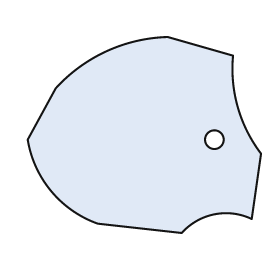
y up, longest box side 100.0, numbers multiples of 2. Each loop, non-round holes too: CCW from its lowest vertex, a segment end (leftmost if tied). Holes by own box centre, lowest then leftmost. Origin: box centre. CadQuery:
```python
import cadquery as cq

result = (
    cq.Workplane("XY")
    .moveTo(16.0, -42.0)
    .threePointArc((30.0, -34.0), (46.0, -36.0))
    .lineTo(50.0, -8.0)
    .threePointArc((40.0, 12.0), (38.0, 34.0))
    .lineTo(10.0, 42.0)
    .threePointArc((-16.0, 36.0), (-38.0, 20.0))
    .lineTo(-50.0, -2.0)
    .threePointArc((-40.0, -24.0), (-20.0, -38.0))
    .close()
    .moveTo(30.0, -2.0)
    .circle(4.0)
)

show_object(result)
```